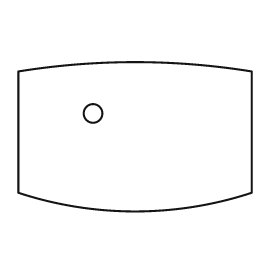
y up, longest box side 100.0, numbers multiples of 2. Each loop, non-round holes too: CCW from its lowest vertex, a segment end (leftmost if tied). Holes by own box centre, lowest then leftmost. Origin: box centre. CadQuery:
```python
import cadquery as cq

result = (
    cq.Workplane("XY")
    .moveTo(-50.0, -24.0)
    .threePointArc((0.0, -32.0), (50.0, -24.0))
    .lineTo(50.0, 28.0)
    .threePointArc((0.0, 32.0), (-50.0, 28.0))
    .close()
    .moveTo(-18.0, 10.0)
    .circle(4.0)
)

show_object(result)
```